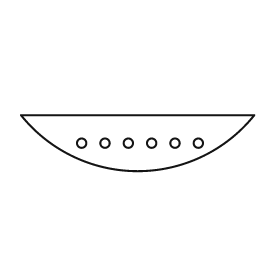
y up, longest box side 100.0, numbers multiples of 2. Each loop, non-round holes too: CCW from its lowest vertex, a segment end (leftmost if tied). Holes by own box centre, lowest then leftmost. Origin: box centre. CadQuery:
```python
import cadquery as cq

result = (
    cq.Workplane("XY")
    .moveTo(-50.0, 12.0)
    .threePointArc((0.0, -12.0), (50.0, 12.0))
    .close()
    .moveTo(-24.0, 0.0)
    .circle(2.0)
    .moveTo(-14.0, 0.0)
    .circle(2.0)
    .moveTo(-4.0, 0.0)
    .circle(2.0)
    .moveTo(6.0, 0.0)
    .circle(2.0)
    .moveTo(16.0, 0.0)
    .circle(2.0)
    .moveTo(26.0, 0.0)
    .circle(2.0)
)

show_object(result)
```